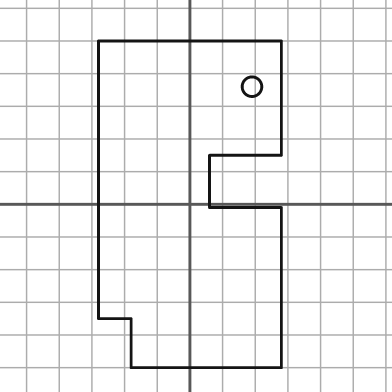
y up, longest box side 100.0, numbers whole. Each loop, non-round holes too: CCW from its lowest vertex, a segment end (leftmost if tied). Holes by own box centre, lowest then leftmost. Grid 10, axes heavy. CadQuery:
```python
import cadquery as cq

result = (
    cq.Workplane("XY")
    .moveTo(-18.0, -50.0)
    .lineTo(28.0, -50.0)
    .lineTo(28.0, -1.0)
    .lineTo(6.0, -1.0)
    .lineTo(6.0, 15.0)
    .lineTo(28.0, 15.0)
    .lineTo(28.0, 50.0)
    .lineTo(-28.0, 50.0)
    .lineTo(-28.0, -35.0)
    .lineTo(-18.0, -35.0)
    .close()
    .moveTo(19.0, 36.0)
    .circle(3.0)
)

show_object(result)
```